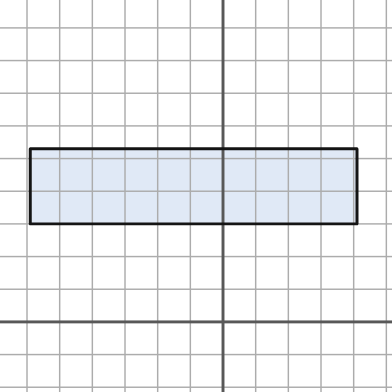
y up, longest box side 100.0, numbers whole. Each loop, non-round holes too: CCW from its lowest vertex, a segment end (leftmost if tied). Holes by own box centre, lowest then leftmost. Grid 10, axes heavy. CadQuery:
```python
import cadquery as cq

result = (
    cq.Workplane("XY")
    .moveTo(-59.0, 30.0)
    .lineTo(41.0, 30.0)
    .lineTo(41.0, 53.0)
    .lineTo(-59.0, 53.0)
    .close()
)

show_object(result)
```